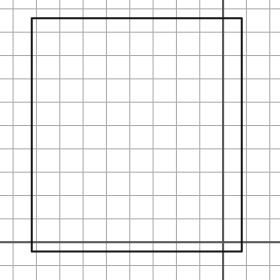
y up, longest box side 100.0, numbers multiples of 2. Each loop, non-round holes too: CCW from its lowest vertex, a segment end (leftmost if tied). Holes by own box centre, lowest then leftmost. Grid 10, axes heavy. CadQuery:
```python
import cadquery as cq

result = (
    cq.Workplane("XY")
    .moveTo(-82.0, -4.0)
    .lineTo(8.0, -4.0)
    .lineTo(8.0, 96.0)
    .lineTo(-82.0, 96.0)
    .close()
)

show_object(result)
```